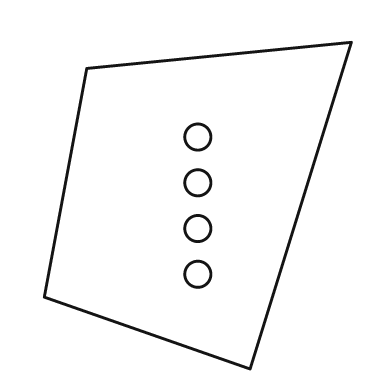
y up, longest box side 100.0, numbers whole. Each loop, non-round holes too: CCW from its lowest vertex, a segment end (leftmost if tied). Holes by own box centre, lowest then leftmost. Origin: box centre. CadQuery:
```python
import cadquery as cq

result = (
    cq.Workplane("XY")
    .moveTo(16.0, -50.0)
    .lineTo(47.0, 50.0)
    .lineTo(-34.0, 42.0)
    .lineTo(-47.0, -28.0)
    .close()
    .moveTo(0.0, -21.0)
    .circle(4.0)
    .moveTo(0.0, -7.0)
    .circle(4.0)
    .moveTo(0.0, 7.0)
    .circle(4.0)
    .moveTo(0.0, 21.0)
    .circle(4.0)
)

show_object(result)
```